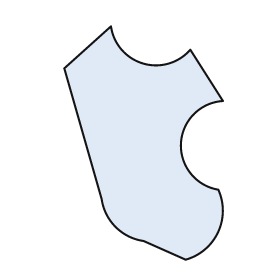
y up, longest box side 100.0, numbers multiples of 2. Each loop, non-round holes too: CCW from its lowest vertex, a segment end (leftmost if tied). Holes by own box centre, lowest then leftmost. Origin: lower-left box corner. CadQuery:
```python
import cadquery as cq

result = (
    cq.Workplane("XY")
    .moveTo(52.0, 0.0)
    .threePointArc((66.0, 12.0), (66.0, 30.0))
    .threePointArc((50.0, 50.0), (68.0, 68.0))
    .lineTo(54.0, 90.0)
    .threePointArc((34.0, 84.0), (20.0, 100.0))
    .lineTo(0.0, 82.0)
    .lineTo(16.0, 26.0)
    .threePointArc((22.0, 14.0), (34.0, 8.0))
    .close()
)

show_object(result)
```